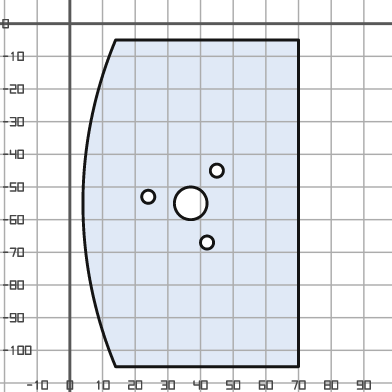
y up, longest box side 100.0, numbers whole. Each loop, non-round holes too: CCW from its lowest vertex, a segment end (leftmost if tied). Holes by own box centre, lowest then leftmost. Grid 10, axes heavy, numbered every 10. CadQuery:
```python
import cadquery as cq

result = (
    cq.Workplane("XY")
    .moveTo(14.0, -105.0)
    .lineTo(70.0, -105.0)
    .lineTo(70.0, -5.0)
    .lineTo(14.0, -5.0)
    .threePointArc((4.0, -55.0), (14.0, -105.0))
    .close()
    .moveTo(42.0, -67.0)
    .circle(2.0)
    .moveTo(37.0, -55.0)
    .circle(5.0)
    .moveTo(24.0, -53.0)
    .circle(2.0)
    .moveTo(45.0, -45.0)
    .circle(2.0)
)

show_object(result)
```